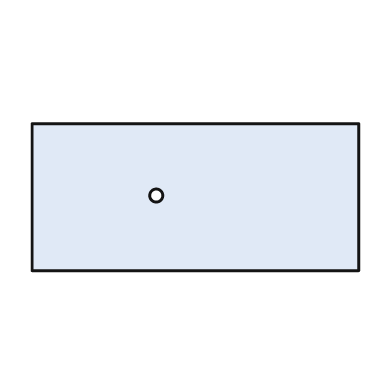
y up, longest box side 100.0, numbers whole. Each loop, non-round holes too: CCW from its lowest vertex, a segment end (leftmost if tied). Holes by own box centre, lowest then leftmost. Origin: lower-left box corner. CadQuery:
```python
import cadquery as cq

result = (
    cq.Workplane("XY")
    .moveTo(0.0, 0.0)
    .lineTo(100.0, 0.0)
    .lineTo(100.0, 45.0)
    .lineTo(0.0, 45.0)
    .close()
    .moveTo(38.0, 23.0)
    .circle(2.0)
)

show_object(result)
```